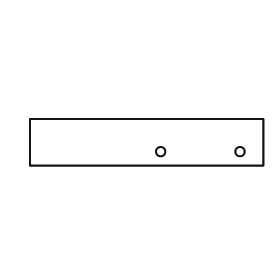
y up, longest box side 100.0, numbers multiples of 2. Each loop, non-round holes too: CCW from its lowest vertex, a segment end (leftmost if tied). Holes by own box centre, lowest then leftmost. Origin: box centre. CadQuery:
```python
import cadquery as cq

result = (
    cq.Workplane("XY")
    .moveTo(-50.0, -10.0)
    .lineTo(50.0, -10.0)
    .lineTo(50.0, 10.0)
    .lineTo(-50.0, 10.0)
    .close()
    .moveTo(6.0, -4.0)
    .circle(2.0)
    .moveTo(40.0, -4.0)
    .circle(2.0)
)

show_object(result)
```